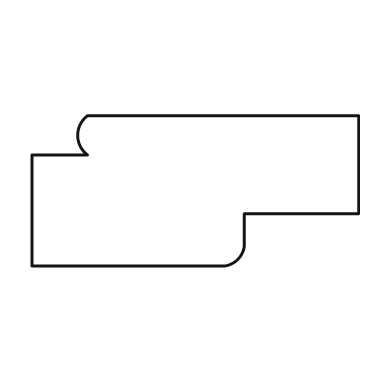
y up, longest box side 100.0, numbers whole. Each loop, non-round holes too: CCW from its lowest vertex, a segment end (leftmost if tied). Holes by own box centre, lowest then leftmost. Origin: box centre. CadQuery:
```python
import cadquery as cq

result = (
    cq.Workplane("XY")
    .moveTo(-50.0, -23.0)
    .lineTo(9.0, -23.0)
    .threePointArc((13.0, -21.0), (15.0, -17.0))
    .lineTo(15.0, -7.0)
    .lineTo(50.0, -7.0)
    .lineTo(50.0, 23.0)
    .lineTo(-33.0, 23.0)
    .threePointArc((-36.0, 17.0), (-33.0, 11.0))
    .lineTo(-50.0, 11.0)
    .close()
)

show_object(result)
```